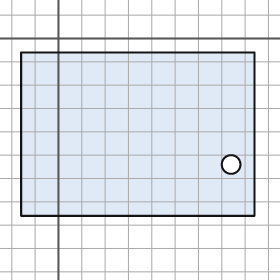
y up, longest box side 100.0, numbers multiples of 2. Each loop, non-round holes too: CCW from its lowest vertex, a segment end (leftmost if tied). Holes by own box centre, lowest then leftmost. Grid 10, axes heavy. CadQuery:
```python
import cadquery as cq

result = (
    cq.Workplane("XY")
    .moveTo(-16.0, -76.0)
    .lineTo(84.0, -76.0)
    .lineTo(84.0, -6.0)
    .lineTo(-16.0, -6.0)
    .close()
    .moveTo(74.0, -54.0)
    .circle(4.0)
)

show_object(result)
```